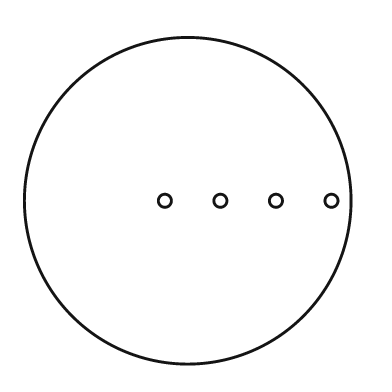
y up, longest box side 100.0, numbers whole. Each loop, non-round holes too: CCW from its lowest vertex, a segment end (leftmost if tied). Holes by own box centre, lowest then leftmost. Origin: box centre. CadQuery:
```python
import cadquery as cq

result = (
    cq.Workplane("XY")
    .moveTo(0.0, 0.0)
    .circle(50.0)
    .moveTo(-7.0, 0.0)
    .circle(2.0)
    .moveTo(10.0, 0.0)
    .circle(2.0)
    .moveTo(27.0, 0.0)
    .circle(2.0)
    .moveTo(44.0, 0.0)
    .circle(2.0)
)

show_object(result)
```